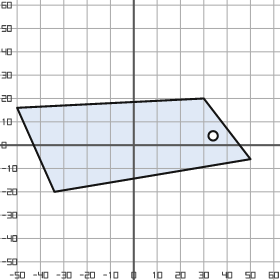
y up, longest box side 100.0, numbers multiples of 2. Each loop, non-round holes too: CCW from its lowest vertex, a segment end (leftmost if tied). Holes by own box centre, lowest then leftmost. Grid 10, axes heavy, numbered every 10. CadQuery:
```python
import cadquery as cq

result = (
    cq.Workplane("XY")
    .moveTo(-34.0, -20.0)
    .lineTo(50.0, -6.0)
    .lineTo(30.0, 20.0)
    .lineTo(-50.0, 16.0)
    .close()
    .moveTo(34.0, 4.0)
    .circle(2.0)
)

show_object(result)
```